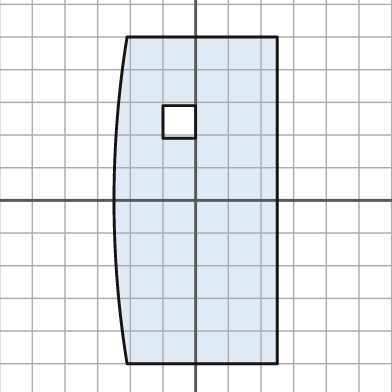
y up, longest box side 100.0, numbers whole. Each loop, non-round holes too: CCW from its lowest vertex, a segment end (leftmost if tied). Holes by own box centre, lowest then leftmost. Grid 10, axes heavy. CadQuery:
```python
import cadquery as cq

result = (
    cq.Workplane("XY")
    .moveTo(-21.0, -50.0)
    .lineTo(25.0, -50.0)
    .lineTo(25.0, 50.0)
    .lineTo(-21.0, 50.0)
    .threePointArc((-25.0, 0.0), (-21.0, -50.0))
    .close()
    .moveTo(-10.0, 19.0)
    .lineTo(0.0, 19.0)
    .lineTo(0.0, 29.0)
    .lineTo(-10.0, 29.0)
    .close()
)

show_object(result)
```